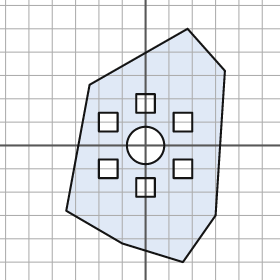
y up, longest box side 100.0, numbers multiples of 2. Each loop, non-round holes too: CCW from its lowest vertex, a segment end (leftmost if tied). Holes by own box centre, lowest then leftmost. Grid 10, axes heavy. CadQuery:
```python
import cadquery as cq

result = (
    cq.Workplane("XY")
    .moveTo(16.0, -50.0)
    .lineTo(30.0, -30.0)
    .lineTo(34.0, 32.0)
    .lineTo(18.0, 50.0)
    .lineTo(-24.0, 26.0)
    .lineTo(-34.0, -28.0)
    .lineTo(-10.0, -42.0)
    .close()
    .moveTo(-4.0, -22.0)
    .lineTo(4.0, -22.0)
    .lineTo(4.0, -14.0)
    .lineTo(-4.0, -14.0)
    .close()
    .moveTo(-20.0, -14.0)
    .lineTo(-12.0, -14.0)
    .lineTo(-12.0, -6.0)
    .lineTo(-20.0, -6.0)
    .close()
    .moveTo(12.0, -14.0)
    .lineTo(20.0, -14.0)
    .lineTo(20.0, -6.0)
    .lineTo(12.0, -6.0)
    .close()
    .moveTo(0.0, 0.0)
    .circle(8.0)
    .moveTo(-20.0, 6.0)
    .lineTo(-12.0, 6.0)
    .lineTo(-12.0, 14.0)
    .lineTo(-20.0, 14.0)
    .close()
    .moveTo(12.0, 6.0)
    .lineTo(20.0, 6.0)
    .lineTo(20.0, 14.0)
    .lineTo(12.0, 14.0)
    .close()
    .moveTo(-4.0, 14.0)
    .lineTo(4.0, 14.0)
    .lineTo(4.0, 22.0)
    .lineTo(-4.0, 22.0)
    .close()
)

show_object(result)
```